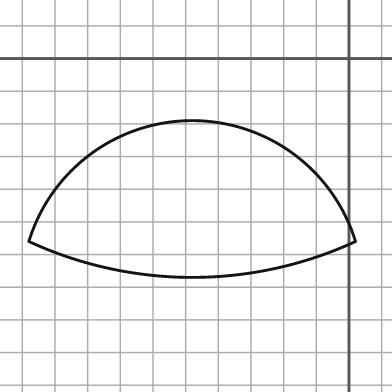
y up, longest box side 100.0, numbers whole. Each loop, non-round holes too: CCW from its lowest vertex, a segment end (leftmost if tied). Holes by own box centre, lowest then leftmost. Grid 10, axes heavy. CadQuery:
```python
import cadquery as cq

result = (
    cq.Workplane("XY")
    .moveTo(-98.0, -56.0)
    .threePointArc((-48.0, -67.0), (2.0, -56.0))
    .threePointArc((-48.0, -19.0), (-98.0, -56.0))
    .close()
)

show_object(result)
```